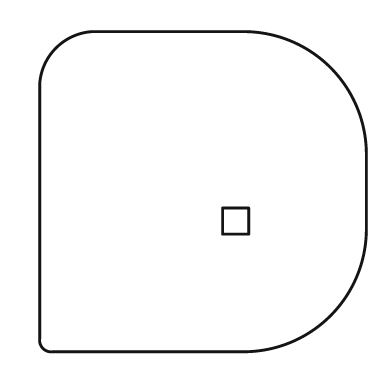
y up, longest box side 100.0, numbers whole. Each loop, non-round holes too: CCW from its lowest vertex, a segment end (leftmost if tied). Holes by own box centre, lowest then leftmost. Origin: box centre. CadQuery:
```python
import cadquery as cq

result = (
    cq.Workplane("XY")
    .moveTo(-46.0, -49.0)
    .lineTo(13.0, -49.0)
    .threePointArc((39.0, -38.0), (50.0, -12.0))
    .lineTo(50.0, 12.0)
    .threePointArc((39.0, 38.0), (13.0, 49.0))
    .lineTo(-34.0, 49.0)
    .threePointArc((-45.0, 44.0), (-50.0, 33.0))
    .lineTo(-50.0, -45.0)
    .threePointArc((-49.0, -48.0), (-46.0, -49.0))
    .close()
    .moveTo(6.0, -13.0)
    .lineTo(14.0, -13.0)
    .lineTo(14.0, -5.0)
    .lineTo(6.0, -5.0)
    .close()
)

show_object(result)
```